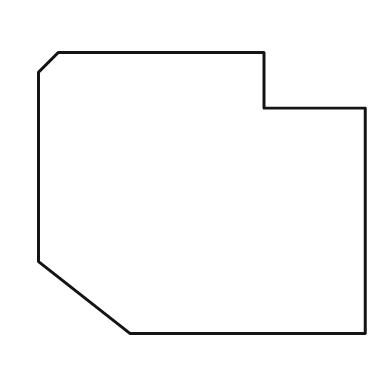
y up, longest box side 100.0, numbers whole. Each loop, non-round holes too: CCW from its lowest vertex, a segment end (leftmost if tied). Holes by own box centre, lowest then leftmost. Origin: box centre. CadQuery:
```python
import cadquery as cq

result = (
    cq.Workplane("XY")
    .moveTo(-22.0, -43.0)
    .lineTo(50.0, -43.0)
    .lineTo(50.0, 26.0)
    .lineTo(19.0, 26.0)
    .lineTo(19.0, 43.0)
    .lineTo(-44.0, 43.0)
    .lineTo(-50.0, 37.0)
    .lineTo(-50.0, -21.0)
    .close()
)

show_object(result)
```